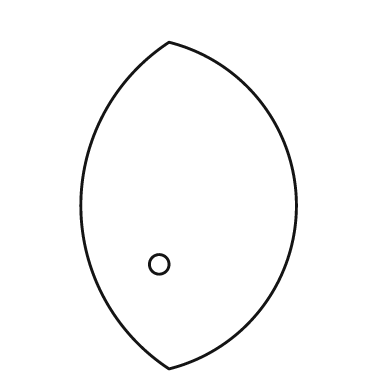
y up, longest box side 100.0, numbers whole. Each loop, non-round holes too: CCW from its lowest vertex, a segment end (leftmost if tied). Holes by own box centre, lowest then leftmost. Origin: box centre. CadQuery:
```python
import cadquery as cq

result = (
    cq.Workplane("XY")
    .moveTo(-6.0, -50.0)
    .threePointArc((33.0, 0.0), (-6.0, 50.0))
    .threePointArc((-33.0, 0.0), (-6.0, -50.0))
    .close()
    .moveTo(-9.0, -18.0)
    .circle(3.0)
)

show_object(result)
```